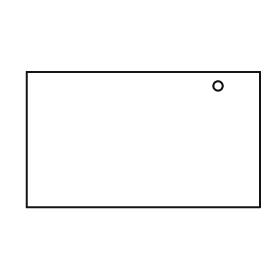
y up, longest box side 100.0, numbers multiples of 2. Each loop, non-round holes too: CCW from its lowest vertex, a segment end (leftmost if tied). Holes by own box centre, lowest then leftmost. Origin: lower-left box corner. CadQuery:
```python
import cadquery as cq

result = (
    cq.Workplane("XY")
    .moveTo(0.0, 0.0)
    .lineTo(100.0, 0.0)
    .lineTo(100.0, 58.0)
    .lineTo(0.0, 58.0)
    .close()
    .moveTo(82.0, 52.0)
    .circle(2.0)
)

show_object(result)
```